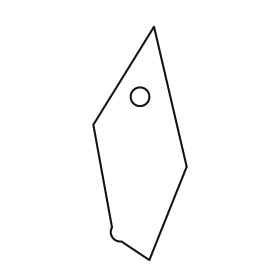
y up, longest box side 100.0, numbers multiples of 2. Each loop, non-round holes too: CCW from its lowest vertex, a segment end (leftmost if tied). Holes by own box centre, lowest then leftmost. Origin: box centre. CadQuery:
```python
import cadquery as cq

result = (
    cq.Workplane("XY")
    .moveTo(4.0, -50.0)
    .lineTo(20.0, -10.0)
    .lineTo(6.0, 50.0)
    .lineTo(-20.0, 8.0)
    .lineTo(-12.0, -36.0)
    .threePointArc((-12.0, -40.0), (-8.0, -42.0))
    .close()
    .moveTo(0.0, 20.0)
    .circle(4.0)
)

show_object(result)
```